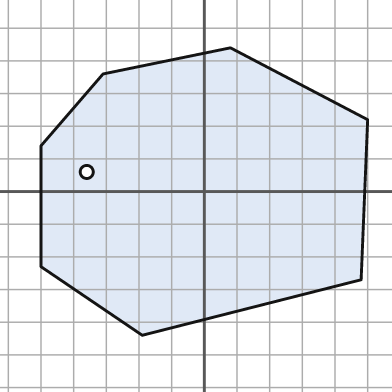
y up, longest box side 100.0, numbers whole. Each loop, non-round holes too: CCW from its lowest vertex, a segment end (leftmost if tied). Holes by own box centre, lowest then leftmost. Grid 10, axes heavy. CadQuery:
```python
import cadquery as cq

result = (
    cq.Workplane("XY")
    .moveTo(-19.0, -44.0)
    .lineTo(48.0, -27.0)
    .lineTo(50.0, 22.0)
    .lineTo(8.0, 44.0)
    .lineTo(-31.0, 36.0)
    .lineTo(-50.0, 14.0)
    .lineTo(-50.0, -23.0)
    .close()
    .moveTo(-36.0, 6.0)
    .circle(2.0)
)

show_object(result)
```